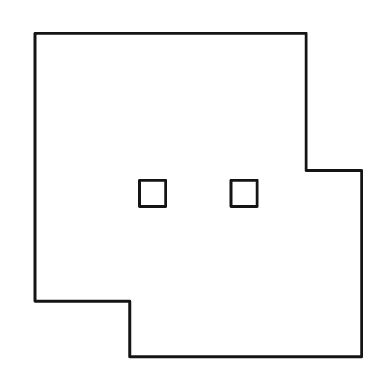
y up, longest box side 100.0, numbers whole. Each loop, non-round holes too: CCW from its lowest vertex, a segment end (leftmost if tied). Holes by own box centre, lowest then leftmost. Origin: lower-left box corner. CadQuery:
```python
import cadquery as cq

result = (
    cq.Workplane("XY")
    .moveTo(29.0, 0.0)
    .lineTo(100.0, 0.0)
    .lineTo(100.0, 57.0)
    .lineTo(83.0, 57.0)
    .lineTo(83.0, 99.0)
    .lineTo(0.0, 99.0)
    .lineTo(0.0, 17.0)
    .lineTo(29.0, 17.0)
    .close()
    .moveTo(32.0, 46.0)
    .lineTo(40.0, 46.0)
    .lineTo(40.0, 54.0)
    .lineTo(32.0, 54.0)
    .close()
    .moveTo(60.0, 46.0)
    .lineTo(68.0, 46.0)
    .lineTo(68.0, 54.0)
    .lineTo(60.0, 54.0)
    .close()
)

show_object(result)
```